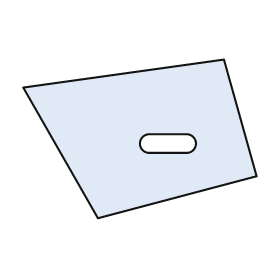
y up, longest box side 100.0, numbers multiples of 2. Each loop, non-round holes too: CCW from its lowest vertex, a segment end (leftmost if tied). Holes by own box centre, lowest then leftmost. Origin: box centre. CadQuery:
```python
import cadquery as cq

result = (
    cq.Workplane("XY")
    .moveTo(-18.0, -34.0)
    .lineTo(50.0, -16.0)
    .lineTo(36.0, 34.0)
    .lineTo(-50.0, 22.0)
    .close()
    .moveTo(4.0, -6.0)
    .lineTo(20.0, -6.0)
    .threePointArc((24.0, -2.0), (20.0, 2.0))
    .lineTo(4.0, 2.0)
    .threePointArc((0.0, -2.0), (4.0, -6.0))
    .close()
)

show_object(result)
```